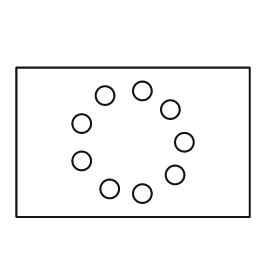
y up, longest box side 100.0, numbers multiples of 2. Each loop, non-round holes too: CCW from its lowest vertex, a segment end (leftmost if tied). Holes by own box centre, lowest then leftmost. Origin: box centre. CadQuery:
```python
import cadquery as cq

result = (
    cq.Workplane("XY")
    .moveTo(-50.0, -32.0)
    .lineTo(50.0, -32.0)
    .lineTo(50.0, 32.0)
    .lineTo(-50.0, 32.0)
    .close()
    .moveTo(4.0, -22.0)
    .circle(4.0)
    .moveTo(-10.0, -20.0)
    .circle(4.0)
    .moveTo(18.0, -14.0)
    .circle(4.0)
    .moveTo(-22.0, -8.0)
    .circle(4.0)
    .moveTo(22.0, 0.0)
    .circle(4.0)
    .moveTo(-22.0, 8.0)
    .circle(4.0)
    .moveTo(16.0, 14.0)
    .circle(4.0)
    .moveTo(-12.0, 20.0)
    .circle(4.0)
    .moveTo(4.0, 22.0)
    .circle(4.0)
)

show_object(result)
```